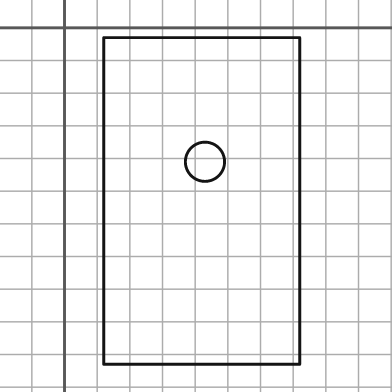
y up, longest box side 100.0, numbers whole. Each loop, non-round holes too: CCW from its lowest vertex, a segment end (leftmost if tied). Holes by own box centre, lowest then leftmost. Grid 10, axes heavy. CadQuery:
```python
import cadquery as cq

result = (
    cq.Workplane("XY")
    .moveTo(12.0, -103.0)
    .lineTo(72.0, -103.0)
    .lineTo(72.0, -3.0)
    .lineTo(12.0, -3.0)
    .close()
    .moveTo(43.0, -41.0)
    .circle(6.0)
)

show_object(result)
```